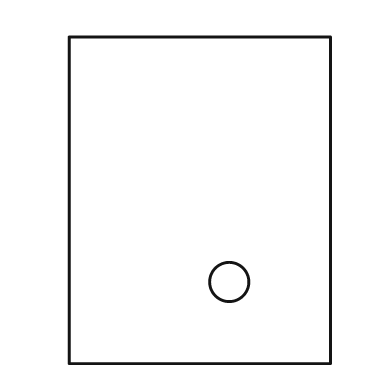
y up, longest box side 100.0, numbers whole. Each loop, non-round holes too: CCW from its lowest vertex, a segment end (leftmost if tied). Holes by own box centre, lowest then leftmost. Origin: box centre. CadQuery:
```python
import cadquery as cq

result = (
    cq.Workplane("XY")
    .moveTo(-40.0, -50.0)
    .lineTo(40.0, -50.0)
    .lineTo(40.0, 50.0)
    .lineTo(-40.0, 50.0)
    .close()
    .moveTo(9.0, -25.0)
    .circle(6.0)
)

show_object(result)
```